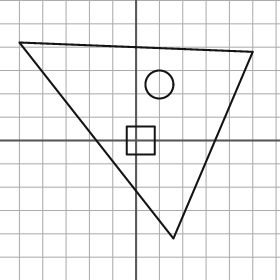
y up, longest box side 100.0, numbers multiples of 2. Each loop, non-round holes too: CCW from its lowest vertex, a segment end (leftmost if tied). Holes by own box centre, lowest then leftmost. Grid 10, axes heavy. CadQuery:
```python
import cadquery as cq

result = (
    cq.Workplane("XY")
    .moveTo(16.0, -42.0)
    .lineTo(50.0, 38.0)
    .lineTo(-50.0, 42.0)
    .close()
    .moveTo(-4.0, -6.0)
    .lineTo(8.0, -6.0)
    .lineTo(8.0, 6.0)
    .lineTo(-4.0, 6.0)
    .close()
    .moveTo(10.0, 24.0)
    .circle(6.0)
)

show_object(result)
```